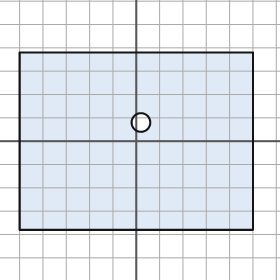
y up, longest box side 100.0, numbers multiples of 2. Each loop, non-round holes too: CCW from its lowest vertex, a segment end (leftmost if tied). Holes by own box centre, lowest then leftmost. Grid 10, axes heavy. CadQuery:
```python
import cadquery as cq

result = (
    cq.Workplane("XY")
    .moveTo(-50.0, -38.0)
    .lineTo(50.0, -38.0)
    .lineTo(50.0, 38.0)
    .lineTo(-50.0, 38.0)
    .close()
    .moveTo(2.0, 8.0)
    .circle(4.0)
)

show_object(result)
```